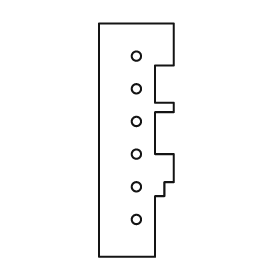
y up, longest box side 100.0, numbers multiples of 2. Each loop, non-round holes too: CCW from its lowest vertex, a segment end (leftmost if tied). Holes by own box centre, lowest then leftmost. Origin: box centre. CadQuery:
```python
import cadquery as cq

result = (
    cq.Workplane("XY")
    .moveTo(-16.0, -50.0)
    .lineTo(8.0, -50.0)
    .lineTo(8.0, -24.0)
    .lineTo(12.0, -24.0)
    .lineTo(12.0, -18.0)
    .lineTo(16.0, -18.0)
    .lineTo(16.0, -6.0)
    .lineTo(8.0, -6.0)
    .lineTo(8.0, 12.0)
    .lineTo(16.0, 12.0)
    .lineTo(16.0, 16.0)
    .lineTo(8.0, 16.0)
    .lineTo(8.0, 32.0)
    .lineTo(16.0, 32.0)
    .lineTo(16.0, 50.0)
    .lineTo(-16.0, 50.0)
    .close()
    .moveTo(0.0, -34.0)
    .circle(2.0)
    .moveTo(0.0, -20.0)
    .circle(2.0)
    .moveTo(0.0, -6.0)
    .circle(2.0)
    .moveTo(0.0, 8.0)
    .circle(2.0)
    .moveTo(0.0, 22.0)
    .circle(2.0)
    .moveTo(0.0, 36.0)
    .circle(2.0)
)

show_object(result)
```